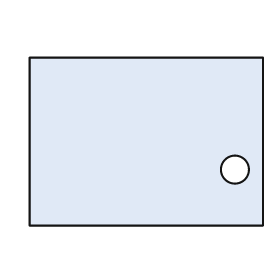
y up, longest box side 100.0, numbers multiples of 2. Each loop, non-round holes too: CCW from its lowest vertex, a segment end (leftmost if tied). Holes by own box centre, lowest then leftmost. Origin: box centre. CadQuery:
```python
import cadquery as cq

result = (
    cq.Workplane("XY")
    .moveTo(-50.0, -36.0)
    .lineTo(50.0, -36.0)
    .lineTo(50.0, 36.0)
    .lineTo(-50.0, 36.0)
    .close()
    .moveTo(38.0, -12.0)
    .circle(6.0)
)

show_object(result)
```